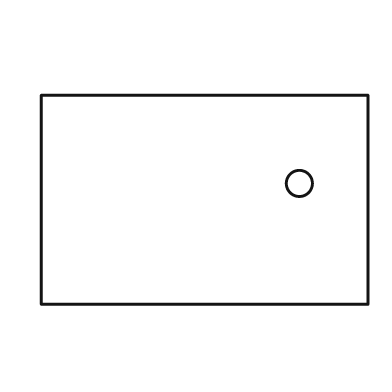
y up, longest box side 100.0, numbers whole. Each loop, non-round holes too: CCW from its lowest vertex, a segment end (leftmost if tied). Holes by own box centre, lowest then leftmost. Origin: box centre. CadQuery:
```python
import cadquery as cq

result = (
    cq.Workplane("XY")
    .moveTo(-50.0, -32.0)
    .lineTo(50.0, -32.0)
    .lineTo(50.0, 32.0)
    .lineTo(-50.0, 32.0)
    .close()
    .moveTo(29.0, 5.0)
    .circle(4.0)
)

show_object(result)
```